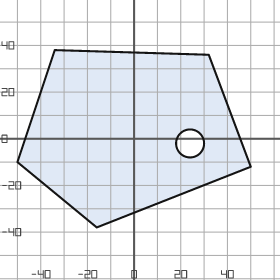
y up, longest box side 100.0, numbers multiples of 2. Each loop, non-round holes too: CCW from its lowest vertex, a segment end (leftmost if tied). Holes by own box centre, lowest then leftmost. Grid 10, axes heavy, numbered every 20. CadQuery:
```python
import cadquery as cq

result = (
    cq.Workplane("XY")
    .moveTo(-16.0, -38.0)
    .lineTo(50.0, -12.0)
    .lineTo(32.0, 36.0)
    .lineTo(-34.0, 38.0)
    .lineTo(-50.0, -10.0)
    .close()
    .moveTo(24.0, -2.0)
    .circle(6.0)
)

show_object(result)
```